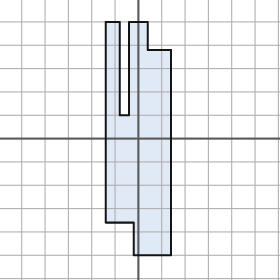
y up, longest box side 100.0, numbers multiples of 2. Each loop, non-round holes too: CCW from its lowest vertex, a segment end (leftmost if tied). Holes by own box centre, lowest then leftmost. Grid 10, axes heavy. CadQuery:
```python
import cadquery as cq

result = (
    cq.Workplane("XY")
    .moveTo(-2.0, -50.0)
    .lineTo(14.0, -50.0)
    .lineTo(14.0, 38.0)
    .lineTo(4.0, 38.0)
    .lineTo(4.0, 50.0)
    .lineTo(-4.0, 50.0)
    .lineTo(-4.0, 10.0)
    .lineTo(-8.0, 10.0)
    .lineTo(-8.0, 50.0)
    .lineTo(-14.0, 50.0)
    .lineTo(-14.0, -36.0)
    .lineTo(-2.0, -36.0)
    .close()
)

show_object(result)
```